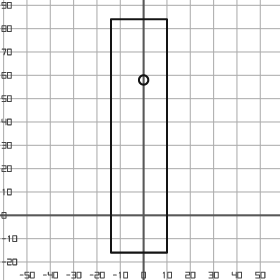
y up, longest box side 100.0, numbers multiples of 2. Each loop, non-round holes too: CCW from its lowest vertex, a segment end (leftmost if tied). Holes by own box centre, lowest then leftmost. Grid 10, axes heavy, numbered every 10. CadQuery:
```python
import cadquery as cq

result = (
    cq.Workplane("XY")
    .moveTo(-14.0, -16.0)
    .lineTo(10.0, -16.0)
    .lineTo(10.0, 84.0)
    .lineTo(-14.0, 84.0)
    .close()
    .moveTo(0.0, 58.0)
    .circle(2.0)
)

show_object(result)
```